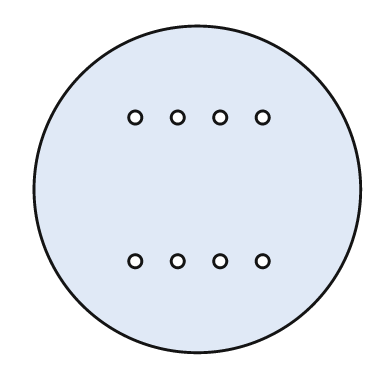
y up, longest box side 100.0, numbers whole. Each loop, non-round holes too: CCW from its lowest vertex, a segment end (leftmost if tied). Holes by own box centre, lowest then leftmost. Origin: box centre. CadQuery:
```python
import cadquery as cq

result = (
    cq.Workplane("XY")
    .moveTo(0.0, 0.0)
    .circle(50.0)
    .moveTo(-19.0, -22.0)
    .circle(2.0)
    .moveTo(-6.0, -22.0)
    .circle(2.0)
    .moveTo(7.0, -22.0)
    .circle(2.0)
    .moveTo(20.0, -22.0)
    .circle(2.0)
    .moveTo(-19.0, 22.0)
    .circle(2.0)
    .moveTo(-6.0, 22.0)
    .circle(2.0)
    .moveTo(7.0, 22.0)
    .circle(2.0)
    .moveTo(20.0, 22.0)
    .circle(2.0)
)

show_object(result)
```